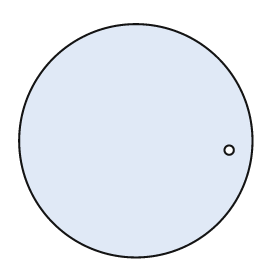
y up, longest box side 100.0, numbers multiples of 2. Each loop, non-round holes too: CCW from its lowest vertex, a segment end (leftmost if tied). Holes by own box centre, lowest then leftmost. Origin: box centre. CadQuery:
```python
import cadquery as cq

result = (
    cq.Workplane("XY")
    .moveTo(0.0, 0.0)
    .circle(50.0)
    .moveTo(40.0, -4.0)
    .circle(2.0)
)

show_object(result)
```